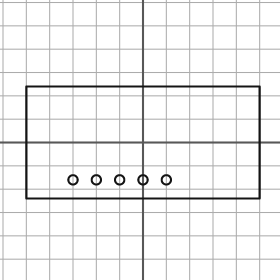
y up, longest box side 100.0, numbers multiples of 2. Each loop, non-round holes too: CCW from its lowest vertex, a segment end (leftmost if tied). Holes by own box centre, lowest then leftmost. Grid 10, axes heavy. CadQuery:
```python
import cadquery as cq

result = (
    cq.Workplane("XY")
    .moveTo(-50.0, -24.0)
    .lineTo(50.0, -24.0)
    .lineTo(50.0, 24.0)
    .lineTo(-50.0, 24.0)
    .close()
    .moveTo(-30.0, -16.0)
    .circle(2.0)
    .moveTo(-20.0, -16.0)
    .circle(2.0)
    .moveTo(-10.0, -16.0)
    .circle(2.0)
    .moveTo(0.0, -16.0)
    .circle(2.0)
    .moveTo(10.0, -16.0)
    .circle(2.0)
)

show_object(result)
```